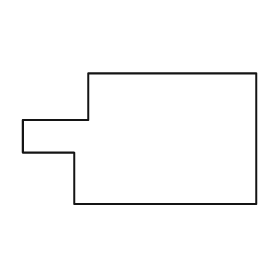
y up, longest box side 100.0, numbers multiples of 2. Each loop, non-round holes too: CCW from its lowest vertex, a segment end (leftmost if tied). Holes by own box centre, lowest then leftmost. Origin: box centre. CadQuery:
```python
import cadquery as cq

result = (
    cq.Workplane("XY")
    .moveTo(-28.0, -28.0)
    .lineTo(50.0, -28.0)
    .lineTo(50.0, 28.0)
    .lineTo(-22.0, 28.0)
    .lineTo(-22.0, 8.0)
    .lineTo(-50.0, 8.0)
    .lineTo(-50.0, -6.0)
    .lineTo(-28.0, -6.0)
    .close()
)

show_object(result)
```